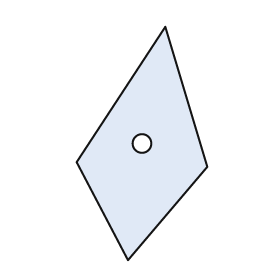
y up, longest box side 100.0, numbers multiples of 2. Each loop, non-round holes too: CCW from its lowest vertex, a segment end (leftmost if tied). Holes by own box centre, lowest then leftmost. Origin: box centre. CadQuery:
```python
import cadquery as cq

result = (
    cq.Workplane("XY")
    .moveTo(-6.0, -50.0)
    .lineTo(28.0, -10.0)
    .lineTo(10.0, 50.0)
    .lineTo(-28.0, -8.0)
    .close()
    .moveTo(0.0, 0.0)
    .circle(4.0)
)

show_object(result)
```